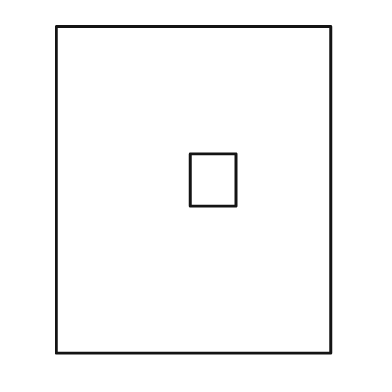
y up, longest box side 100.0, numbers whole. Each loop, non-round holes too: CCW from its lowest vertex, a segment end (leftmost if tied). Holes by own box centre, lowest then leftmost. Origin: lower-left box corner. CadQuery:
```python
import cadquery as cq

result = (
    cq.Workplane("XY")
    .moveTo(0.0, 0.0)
    .lineTo(84.0, 0.0)
    .lineTo(84.0, 100.0)
    .lineTo(0.0, 100.0)
    .close()
    .moveTo(41.0, 45.0)
    .lineTo(55.0, 45.0)
    .lineTo(55.0, 61.0)
    .lineTo(41.0, 61.0)
    .close()
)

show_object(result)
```